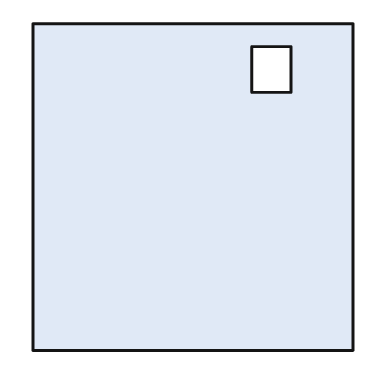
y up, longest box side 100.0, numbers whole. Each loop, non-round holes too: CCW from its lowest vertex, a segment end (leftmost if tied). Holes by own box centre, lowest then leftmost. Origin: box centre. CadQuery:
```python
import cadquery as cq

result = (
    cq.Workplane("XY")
    .moveTo(-49.0, -50.0)
    .lineTo(49.0, -50.0)
    .lineTo(49.0, 50.0)
    .lineTo(-49.0, 50.0)
    .close()
    .moveTo(18.0, 29.0)
    .lineTo(30.0, 29.0)
    .lineTo(30.0, 43.0)
    .lineTo(18.0, 43.0)
    .close()
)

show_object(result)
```